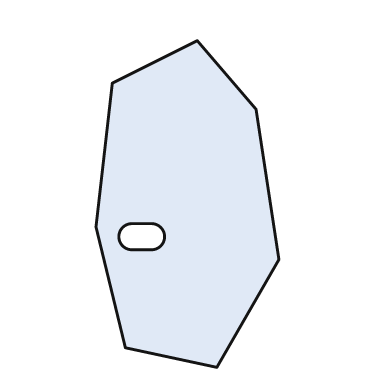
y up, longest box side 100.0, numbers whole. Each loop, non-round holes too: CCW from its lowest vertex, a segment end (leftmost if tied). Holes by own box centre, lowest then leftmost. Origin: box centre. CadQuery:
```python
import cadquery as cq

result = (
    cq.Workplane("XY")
    .moveTo(9.0, -50.0)
    .lineTo(28.0, -17.0)
    .lineTo(21.0, 29.0)
    .lineTo(3.0, 50.0)
    .lineTo(-23.0, 37.0)
    .lineTo(-28.0, -7.0)
    .lineTo(-19.0, -44.0)
    .close()
    .moveTo(-17.0, -14.0)
    .lineTo(-11.0, -14.0)
    .threePointArc((-7.0, -10.0), (-11.0, -6.0))
    .lineTo(-17.0, -6.0)
    .threePointArc((-21.0, -10.0), (-17.0, -14.0))
    .close()
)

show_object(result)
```